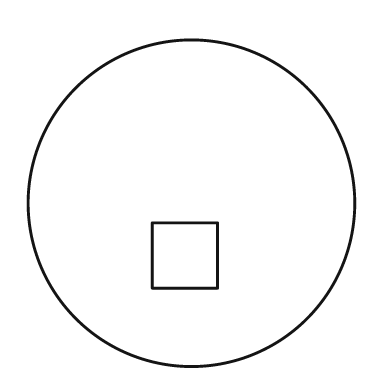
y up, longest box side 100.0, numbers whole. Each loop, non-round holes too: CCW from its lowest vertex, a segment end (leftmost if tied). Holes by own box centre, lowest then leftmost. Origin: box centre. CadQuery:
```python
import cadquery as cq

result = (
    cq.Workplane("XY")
    .moveTo(0.0, 0.0)
    .circle(50.0)
    .moveTo(-12.0, -26.0)
    .lineTo(8.0, -26.0)
    .lineTo(8.0, -6.0)
    .lineTo(-12.0, -6.0)
    .close()
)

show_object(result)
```